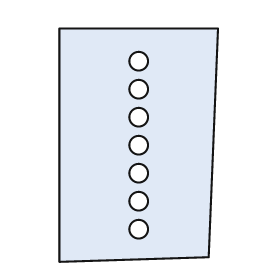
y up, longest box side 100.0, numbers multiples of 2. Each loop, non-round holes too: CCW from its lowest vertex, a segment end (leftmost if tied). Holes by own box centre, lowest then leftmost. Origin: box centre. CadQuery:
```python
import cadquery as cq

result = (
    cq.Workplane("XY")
    .moveTo(-34.0, -50.0)
    .lineTo(30.0, -48.0)
    .lineTo(34.0, 50.0)
    .lineTo(-34.0, 50.0)
    .close()
    .moveTo(0.0, -36.0)
    .circle(4.0)
    .moveTo(0.0, -24.0)
    .circle(4.0)
    .moveTo(0.0, -12.0)
    .circle(4.0)
    .moveTo(0.0, 0.0)
    .circle(4.0)
    .moveTo(0.0, 12.0)
    .circle(4.0)
    .moveTo(0.0, 24.0)
    .circle(4.0)
    .moveTo(0.0, 36.0)
    .circle(4.0)
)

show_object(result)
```